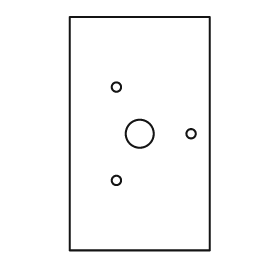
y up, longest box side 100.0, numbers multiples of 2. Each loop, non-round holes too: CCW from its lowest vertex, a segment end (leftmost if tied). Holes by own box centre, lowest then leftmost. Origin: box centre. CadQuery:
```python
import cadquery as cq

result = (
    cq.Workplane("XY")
    .moveTo(-30.0, -50.0)
    .lineTo(30.0, -50.0)
    .lineTo(30.0, 50.0)
    .lineTo(-30.0, 50.0)
    .close()
    .moveTo(-10.0, -20.0)
    .circle(2.0)
    .moveTo(0.0, 0.0)
    .circle(6.0)
    .moveTo(22.0, 0.0)
    .circle(2.0)
    .moveTo(-10.0, 20.0)
    .circle(2.0)
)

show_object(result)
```